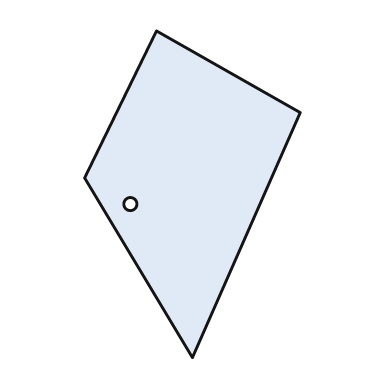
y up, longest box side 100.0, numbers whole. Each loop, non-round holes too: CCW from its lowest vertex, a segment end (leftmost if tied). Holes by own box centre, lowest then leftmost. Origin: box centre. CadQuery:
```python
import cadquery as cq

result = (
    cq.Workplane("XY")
    .moveTo(0.0, -50.0)
    .lineTo(33.0, 25.0)
    .lineTo(-11.0, 50.0)
    .lineTo(-33.0, 5.0)
    .close()
    .moveTo(-19.0, -3.0)
    .circle(2.0)
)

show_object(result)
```